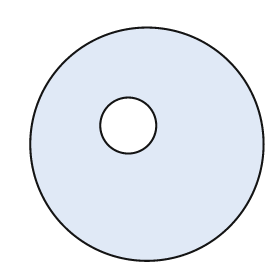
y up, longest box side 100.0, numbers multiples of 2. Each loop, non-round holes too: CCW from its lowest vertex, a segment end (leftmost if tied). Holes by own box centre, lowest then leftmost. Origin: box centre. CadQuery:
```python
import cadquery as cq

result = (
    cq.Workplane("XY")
    .moveTo(0.0, 0.0)
    .circle(50.0)
    .moveTo(-8.0, 8.0)
    .circle(12.0)
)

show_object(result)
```